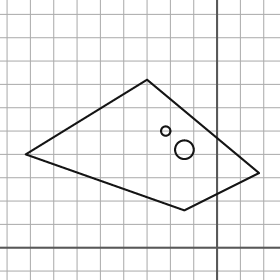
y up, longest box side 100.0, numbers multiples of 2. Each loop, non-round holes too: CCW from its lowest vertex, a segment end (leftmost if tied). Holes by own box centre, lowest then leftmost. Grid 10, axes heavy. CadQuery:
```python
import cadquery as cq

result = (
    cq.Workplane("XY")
    .moveTo(-14.0, 16.0)
    .lineTo(18.0, 32.0)
    .lineTo(-30.0, 72.0)
    .lineTo(-82.0, 40.0)
    .close()
    .moveTo(-14.0, 42.0)
    .circle(4.0)
    .moveTo(-22.0, 50.0)
    .circle(2.0)
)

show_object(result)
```